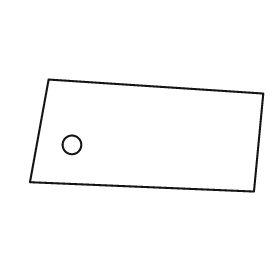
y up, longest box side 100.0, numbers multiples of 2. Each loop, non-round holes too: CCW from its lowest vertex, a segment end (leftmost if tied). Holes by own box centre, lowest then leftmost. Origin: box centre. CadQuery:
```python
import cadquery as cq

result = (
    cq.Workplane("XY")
    .moveTo(46.0, -24.0)
    .lineTo(50.0, 18.0)
    .lineTo(-42.0, 24.0)
    .lineTo(-50.0, -20.0)
    .close()
    .moveTo(-32.0, -4.0)
    .circle(4.0)
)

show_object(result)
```